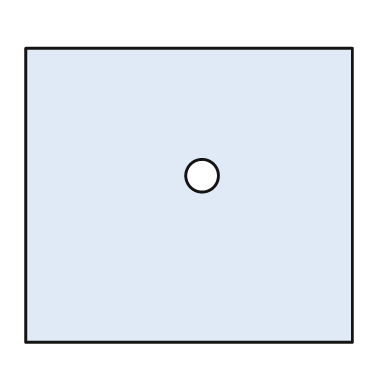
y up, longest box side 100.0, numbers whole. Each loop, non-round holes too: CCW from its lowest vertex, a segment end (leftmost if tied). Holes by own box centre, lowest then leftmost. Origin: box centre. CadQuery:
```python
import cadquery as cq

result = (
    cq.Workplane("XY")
    .moveTo(-50.0, -45.0)
    .lineTo(50.0, -45.0)
    .lineTo(50.0, 45.0)
    .lineTo(-50.0, 45.0)
    .close()
    .moveTo(4.0, 6.0)
    .circle(5.0)
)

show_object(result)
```